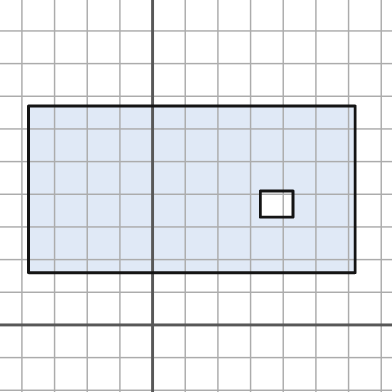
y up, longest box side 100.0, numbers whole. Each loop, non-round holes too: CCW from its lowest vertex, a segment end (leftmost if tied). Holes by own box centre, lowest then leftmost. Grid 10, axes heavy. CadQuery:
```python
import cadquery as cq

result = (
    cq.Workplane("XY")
    .moveTo(-38.0, 16.0)
    .lineTo(62.0, 16.0)
    .lineTo(62.0, 67.0)
    .lineTo(-38.0, 67.0)
    .close()
    .moveTo(33.0, 33.0)
    .lineTo(43.0, 33.0)
    .lineTo(43.0, 41.0)
    .lineTo(33.0, 41.0)
    .close()
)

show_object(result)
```